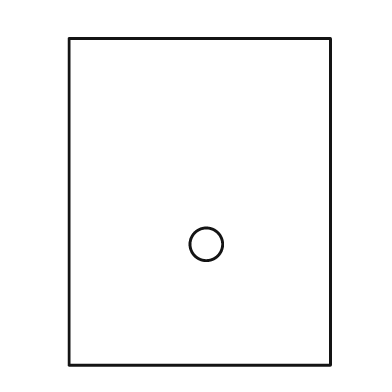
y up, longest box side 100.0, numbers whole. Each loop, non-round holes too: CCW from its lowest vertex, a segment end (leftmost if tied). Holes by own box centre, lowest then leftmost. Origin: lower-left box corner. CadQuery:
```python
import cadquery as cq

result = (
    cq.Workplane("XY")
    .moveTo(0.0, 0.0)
    .lineTo(80.0, 0.0)
    .lineTo(80.0, 100.0)
    .lineTo(0.0, 100.0)
    .close()
    .moveTo(42.0, 37.0)
    .circle(5.0)
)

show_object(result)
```